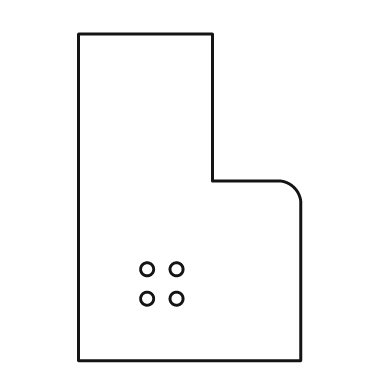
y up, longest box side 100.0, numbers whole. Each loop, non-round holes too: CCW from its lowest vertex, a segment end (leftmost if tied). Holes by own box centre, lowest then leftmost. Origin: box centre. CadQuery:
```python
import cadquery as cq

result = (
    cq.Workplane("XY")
    .moveTo(-34.0, -50.0)
    .lineTo(34.0, -50.0)
    .lineTo(34.0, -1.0)
    .threePointArc((32.0, 3.0), (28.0, 5.0))
    .lineTo(7.0, 5.0)
    .lineTo(7.0, 50.0)
    .lineTo(-34.0, 50.0)
    .close()
    .moveTo(-13.0, -31.0)
    .circle(2.0)
    .moveTo(-4.0, -31.0)
    .circle(2.0)
    .moveTo(-13.0, -22.0)
    .circle(2.0)
    .moveTo(-4.0, -22.0)
    .circle(2.0)
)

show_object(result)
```